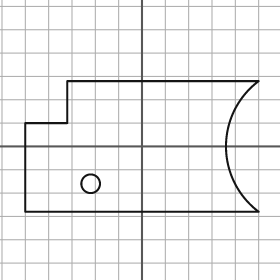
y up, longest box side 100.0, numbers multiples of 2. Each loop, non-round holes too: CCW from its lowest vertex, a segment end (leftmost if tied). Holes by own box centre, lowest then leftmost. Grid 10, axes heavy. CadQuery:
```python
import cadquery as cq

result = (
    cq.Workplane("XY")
    .moveTo(-50.0, -28.0)
    .lineTo(50.0, -28.0)
    .threePointArc((36.0, 0.0), (50.0, 28.0))
    .lineTo(-32.0, 28.0)
    .lineTo(-32.0, 10.0)
    .lineTo(-50.0, 10.0)
    .close()
    .moveTo(-22.0, -16.0)
    .circle(4.0)
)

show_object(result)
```